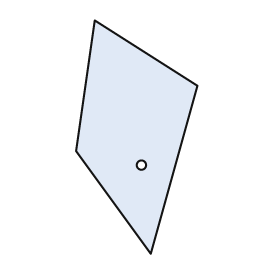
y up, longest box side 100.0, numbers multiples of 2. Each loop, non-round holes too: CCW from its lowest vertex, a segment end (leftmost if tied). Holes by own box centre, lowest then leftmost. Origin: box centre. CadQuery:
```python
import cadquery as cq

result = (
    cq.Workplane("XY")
    .moveTo(6.0, -50.0)
    .lineTo(26.0, 22.0)
    .lineTo(-18.0, 50.0)
    .lineTo(-26.0, -6.0)
    .close()
    .moveTo(2.0, -12.0)
    .circle(2.0)
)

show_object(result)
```